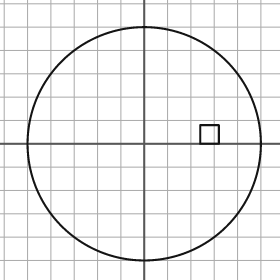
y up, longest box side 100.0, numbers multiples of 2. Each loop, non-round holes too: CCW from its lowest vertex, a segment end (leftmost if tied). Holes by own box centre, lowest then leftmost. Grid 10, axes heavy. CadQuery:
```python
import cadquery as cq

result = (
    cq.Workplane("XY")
    .moveTo(0.0, 0.0)
    .circle(50.0)
    .moveTo(24.0, 0.0)
    .lineTo(32.0, 0.0)
    .lineTo(32.0, 8.0)
    .lineTo(24.0, 8.0)
    .close()
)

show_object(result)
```